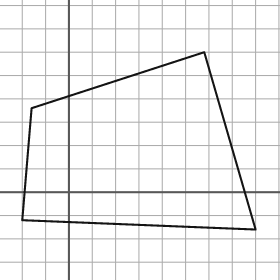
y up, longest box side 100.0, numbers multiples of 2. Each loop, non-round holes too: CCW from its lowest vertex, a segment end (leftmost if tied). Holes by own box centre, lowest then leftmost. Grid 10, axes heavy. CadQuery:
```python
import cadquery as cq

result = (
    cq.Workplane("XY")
    .moveTo(80.0, -16.0)
    .lineTo(58.0, 60.0)
    .lineTo(-16.0, 36.0)
    .lineTo(-20.0, -12.0)
    .close()
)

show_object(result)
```